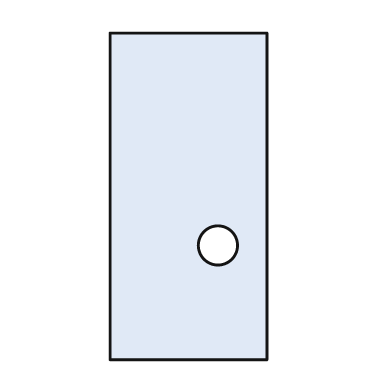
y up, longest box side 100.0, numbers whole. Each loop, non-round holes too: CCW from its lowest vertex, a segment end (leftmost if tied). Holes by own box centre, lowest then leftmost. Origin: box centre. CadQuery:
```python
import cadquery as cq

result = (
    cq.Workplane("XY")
    .moveTo(-24.0, -50.0)
    .lineTo(24.0, -50.0)
    .lineTo(24.0, 50.0)
    .lineTo(-24.0, 50.0)
    .close()
    .moveTo(9.0, -15.0)
    .circle(6.0)
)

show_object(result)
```